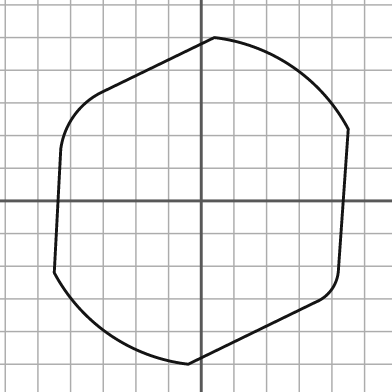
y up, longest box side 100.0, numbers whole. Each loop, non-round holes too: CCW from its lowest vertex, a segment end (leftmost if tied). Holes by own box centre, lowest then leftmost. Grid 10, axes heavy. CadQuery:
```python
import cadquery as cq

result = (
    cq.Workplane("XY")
    .moveTo(-4.0, -50.0)
    .lineTo(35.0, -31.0)
    .threePointArc((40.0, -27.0), (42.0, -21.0))
    .lineTo(45.0, 22.0)
    .threePointArc((28.0, 41.0), (4.0, 50.0))
    .lineTo(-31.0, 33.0)
    .threePointArc((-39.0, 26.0), (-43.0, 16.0))
    .lineTo(-45.0, -22.0)
    .threePointArc((-28.0, -41.0), (-4.0, -50.0))
    .close()
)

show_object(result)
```